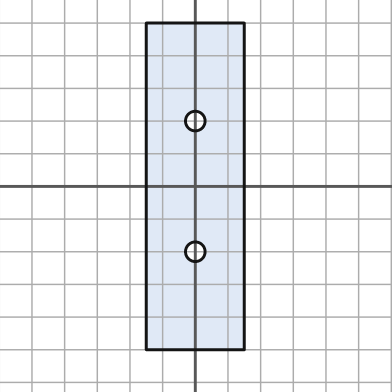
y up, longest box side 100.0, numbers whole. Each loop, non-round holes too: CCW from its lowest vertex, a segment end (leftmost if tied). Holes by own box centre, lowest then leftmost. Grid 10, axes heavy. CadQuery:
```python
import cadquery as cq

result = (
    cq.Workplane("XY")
    .moveTo(-15.0, -50.0)
    .lineTo(15.0, -50.0)
    .lineTo(15.0, 50.0)
    .lineTo(-15.0, 50.0)
    .close()
    .moveTo(0.0, -20.0)
    .circle(3.0)
    .moveTo(0.0, 20.0)
    .circle(3.0)
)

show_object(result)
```